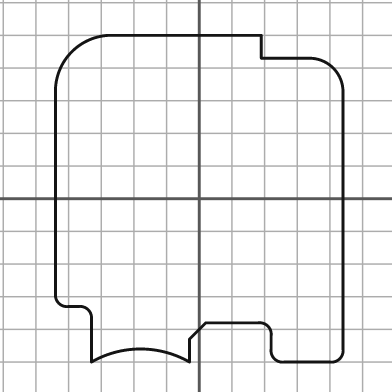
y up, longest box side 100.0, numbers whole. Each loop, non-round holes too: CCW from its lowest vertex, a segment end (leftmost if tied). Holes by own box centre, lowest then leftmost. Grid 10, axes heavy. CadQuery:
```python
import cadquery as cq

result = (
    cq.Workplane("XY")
    .moveTo(-33.0, -50.0)
    .threePointArc((-18.0, -46.0), (-3.0, -50.0))
    .lineTo(-3.0, -43.0)
    .lineTo(2.0, -38.0)
    .lineTo(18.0, -38.0)
    .threePointArc((21.0, -39.0), (22.0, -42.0))
    .lineTo(22.0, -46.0)
    .threePointArc((23.0, -49.0), (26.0, -50.0))
    .lineTo(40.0, -50.0)
    .threePointArc((43.0, -49.0), (44.0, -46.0))
    .lineTo(44.0, 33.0)
    .threePointArc((41.0, 40.0), (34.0, 43.0))
    .lineTo(19.0, 43.0)
    .lineTo(19.0, 50.0)
    .lineTo(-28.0, 50.0)
    .threePointArc((-39.0, 45.0), (-44.0, 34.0))
    .lineTo(-44.0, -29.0)
    .threePointArc((-43.0, -32.0), (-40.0, -33.0))
    .lineTo(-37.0, -33.0)
    .threePointArc((-34.0, -34.0), (-33.0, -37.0))
    .close()
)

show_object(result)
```